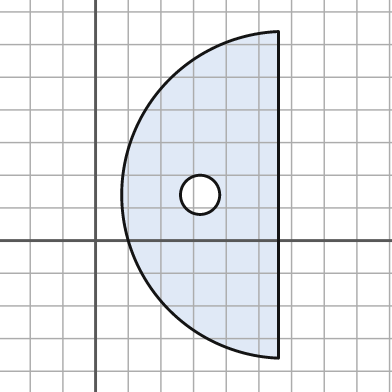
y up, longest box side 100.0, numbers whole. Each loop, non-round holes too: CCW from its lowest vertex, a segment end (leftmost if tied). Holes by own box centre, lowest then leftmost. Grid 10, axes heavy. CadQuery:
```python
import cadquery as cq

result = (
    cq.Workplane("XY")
    .moveTo(56.0, -36.0)
    .lineTo(56.0, 64.0)
    .threePointArc((8.0, 14.0), (56.0, -36.0))
    .close()
    .moveTo(32.0, 14.0)
    .circle(6.0)
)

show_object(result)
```